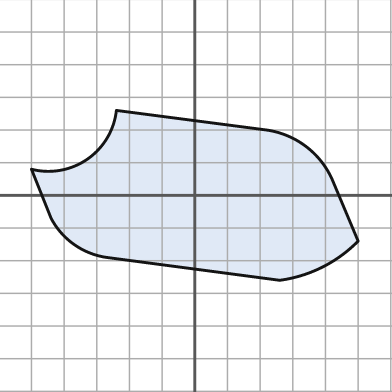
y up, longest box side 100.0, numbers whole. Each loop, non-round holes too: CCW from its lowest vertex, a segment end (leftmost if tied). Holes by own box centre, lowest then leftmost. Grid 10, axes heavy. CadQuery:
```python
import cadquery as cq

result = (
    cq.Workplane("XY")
    .moveTo(26.0, -26.0)
    .threePointArc((39.0, -22.0), (50.0, -14.0))
    .lineTo(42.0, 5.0)
    .threePointArc((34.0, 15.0), (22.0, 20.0))
    .lineTo(-24.0, 26.0)
    .threePointArc((-33.0, 11.0), (-50.0, 8.0))
    .lineTo(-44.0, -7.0)
    .threePointArc((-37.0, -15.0), (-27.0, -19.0))
    .close()
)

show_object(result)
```